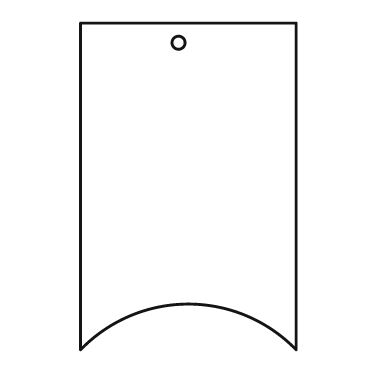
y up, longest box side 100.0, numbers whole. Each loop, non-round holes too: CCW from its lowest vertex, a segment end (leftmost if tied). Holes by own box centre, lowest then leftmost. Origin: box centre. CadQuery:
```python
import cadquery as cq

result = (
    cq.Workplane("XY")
    .moveTo(-33.0, -50.0)
    .threePointArc((0.0, -36.0), (33.0, -50.0))
    .lineTo(33.0, 50.0)
    .lineTo(-33.0, 50.0)
    .close()
    .moveTo(-3.0, 44.0)
    .circle(2.0)
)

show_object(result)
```